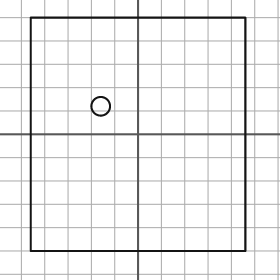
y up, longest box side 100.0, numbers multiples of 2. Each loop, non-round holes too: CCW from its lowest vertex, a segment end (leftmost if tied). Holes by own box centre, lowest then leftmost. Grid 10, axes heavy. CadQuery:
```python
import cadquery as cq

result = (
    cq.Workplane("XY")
    .moveTo(-46.0, -50.0)
    .lineTo(46.0, -50.0)
    .lineTo(46.0, 50.0)
    .lineTo(-46.0, 50.0)
    .close()
    .moveTo(-16.0, 12.0)
    .circle(4.0)
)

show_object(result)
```